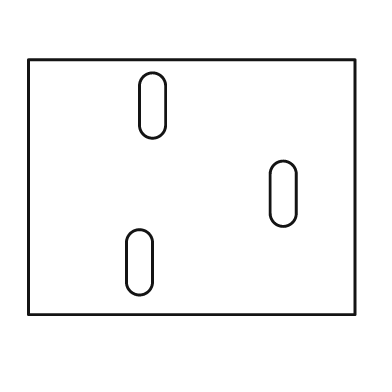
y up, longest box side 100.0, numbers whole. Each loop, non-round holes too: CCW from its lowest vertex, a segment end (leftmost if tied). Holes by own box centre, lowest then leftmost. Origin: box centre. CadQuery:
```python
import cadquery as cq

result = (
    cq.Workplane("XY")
    .moveTo(-50.0, -39.0)
    .lineTo(50.0, -39.0)
    .lineTo(50.0, 39.0)
    .lineTo(-50.0, 39.0)
    .close()
    .moveTo(-20.0, -29.0)
    .threePointArc((-16.0, -33.0), (-12.0, -29.0))
    .lineTo(-12.0, -17.0)
    .threePointArc((-16.0, -13.0), (-20.0, -17.0))
    .close()
    .moveTo(24.0, -8.0)
    .threePointArc((28.0, -12.0), (32.0, -8.0))
    .lineTo(32.0, 4.0)
    .threePointArc((28.0, 8.0), (24.0, 4.0))
    .close()
    .moveTo(-16.0, 19.0)
    .threePointArc((-12.0, 15.0), (-8.0, 19.0))
    .lineTo(-8.0, 31.0)
    .threePointArc((-12.0, 35.0), (-16.0, 31.0))
    .close()
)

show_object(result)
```